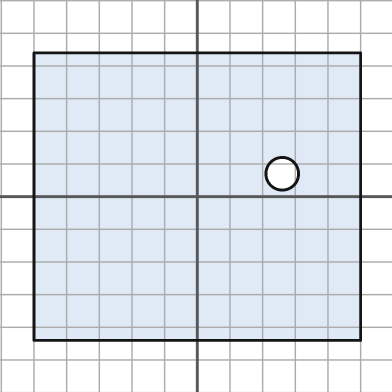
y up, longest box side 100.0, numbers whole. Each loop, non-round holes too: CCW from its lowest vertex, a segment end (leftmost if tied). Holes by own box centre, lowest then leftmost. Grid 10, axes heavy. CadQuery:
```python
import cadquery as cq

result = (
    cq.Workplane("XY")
    .moveTo(-50.0, -44.0)
    .lineTo(50.0, -44.0)
    .lineTo(50.0, 44.0)
    .lineTo(-50.0, 44.0)
    .close()
    .moveTo(26.0, 7.0)
    .circle(5.0)
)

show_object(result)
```